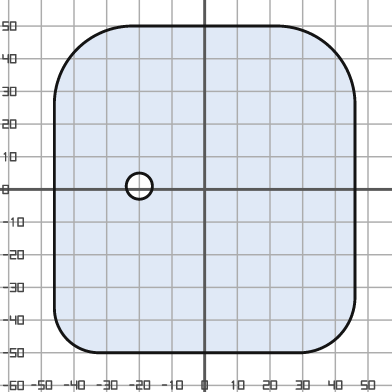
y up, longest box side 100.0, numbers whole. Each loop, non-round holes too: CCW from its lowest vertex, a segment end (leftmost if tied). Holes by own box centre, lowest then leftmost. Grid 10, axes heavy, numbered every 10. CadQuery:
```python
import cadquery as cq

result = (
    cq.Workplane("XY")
    .moveTo(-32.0, -50.0)
    .lineTo(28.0, -50.0)
    .threePointArc((41.0, -45.0), (46.0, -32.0))
    .lineTo(46.0, 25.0)
    .threePointArc((39.0, 43.0), (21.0, 50.0))
    .lineTo(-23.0, 50.0)
    .threePointArc((-39.0, 43.0), (-46.0, 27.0))
    .lineTo(-46.0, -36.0)
    .threePointArc((-42.0, -46.0), (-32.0, -50.0))
    .close()
    .moveTo(-20.0, 1.0)
    .circle(4.0)
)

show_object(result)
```